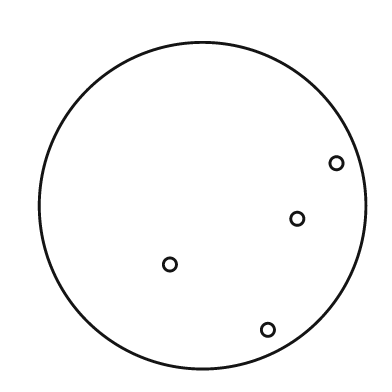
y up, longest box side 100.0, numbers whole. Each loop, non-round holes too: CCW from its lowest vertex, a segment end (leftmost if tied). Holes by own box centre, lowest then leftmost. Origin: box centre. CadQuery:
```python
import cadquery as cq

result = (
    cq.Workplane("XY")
    .moveTo(0.0, 0.0)
    .circle(50.0)
    .moveTo(20.0, -38.0)
    .circle(2.0)
    .moveTo(-10.0, -18.0)
    .circle(2.0)
    .moveTo(29.0, -4.0)
    .circle(2.0)
    .moveTo(41.0, 13.0)
    .circle(2.0)
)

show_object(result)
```